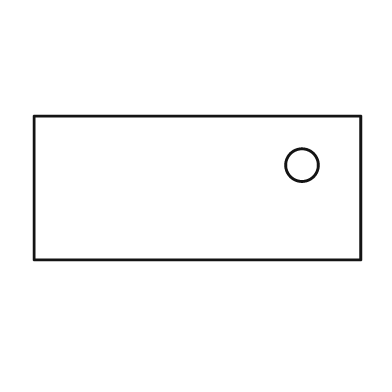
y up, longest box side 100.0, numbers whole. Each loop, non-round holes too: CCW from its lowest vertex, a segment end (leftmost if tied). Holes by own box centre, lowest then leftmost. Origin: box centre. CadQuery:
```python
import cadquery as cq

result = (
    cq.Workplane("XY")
    .moveTo(-50.0, -22.0)
    .lineTo(50.0, -22.0)
    .lineTo(50.0, 22.0)
    .lineTo(-50.0, 22.0)
    .close()
    .moveTo(32.0, 7.0)
    .circle(5.0)
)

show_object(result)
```